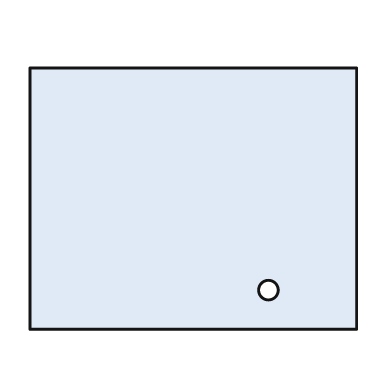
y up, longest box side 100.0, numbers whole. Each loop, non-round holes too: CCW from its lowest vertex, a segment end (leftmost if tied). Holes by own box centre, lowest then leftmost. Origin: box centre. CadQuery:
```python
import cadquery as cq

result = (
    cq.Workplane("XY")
    .moveTo(-50.0, -40.0)
    .lineTo(50.0, -40.0)
    .lineTo(50.0, 40.0)
    .lineTo(-50.0, 40.0)
    .close()
    .moveTo(23.0, -28.0)
    .circle(3.0)
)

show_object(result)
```